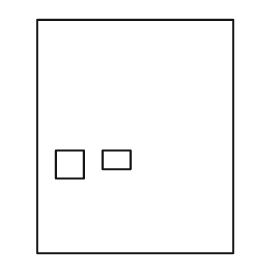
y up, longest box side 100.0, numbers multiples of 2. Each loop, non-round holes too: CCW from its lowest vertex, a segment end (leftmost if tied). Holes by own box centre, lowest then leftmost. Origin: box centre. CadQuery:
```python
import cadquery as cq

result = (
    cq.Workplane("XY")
    .moveTo(-42.0, -50.0)
    .lineTo(42.0, -50.0)
    .lineTo(42.0, 50.0)
    .lineTo(-42.0, 50.0)
    .close()
    .moveTo(-34.0, -18.0)
    .lineTo(-22.0, -18.0)
    .lineTo(-22.0, -6.0)
    .lineTo(-34.0, -6.0)
    .close()
    .moveTo(-14.0, -14.0)
    .lineTo(-2.0, -14.0)
    .lineTo(-2.0, -6.0)
    .lineTo(-14.0, -6.0)
    .close()
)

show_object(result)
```